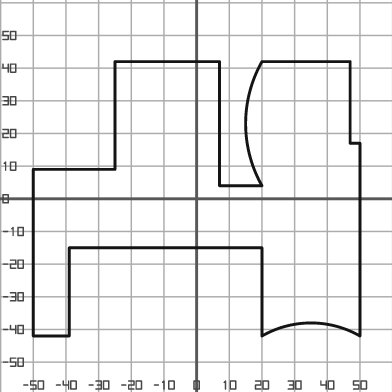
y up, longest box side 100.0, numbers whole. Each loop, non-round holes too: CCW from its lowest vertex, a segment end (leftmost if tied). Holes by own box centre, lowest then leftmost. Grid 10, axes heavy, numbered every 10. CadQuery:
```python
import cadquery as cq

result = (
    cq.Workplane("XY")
    .moveTo(-50.0, -42.0)
    .lineTo(-39.0, -42.0)
    .lineTo(-39.0, -15.0)
    .lineTo(20.0, -15.0)
    .lineTo(20.0, -42.0)
    .threePointArc((35.0, -38.0), (50.0, -42.0))
    .lineTo(50.0, 17.0)
    .lineTo(47.0, 17.0)
    .lineTo(47.0, 42.0)
    .lineTo(20.0, 42.0)
    .threePointArc((15.0, 23.0), (20.0, 4.0))
    .lineTo(7.0, 4.0)
    .lineTo(7.0, 42.0)
    .lineTo(-25.0, 42.0)
    .lineTo(-25.0, 9.0)
    .lineTo(-50.0, 9.0)
    .close()
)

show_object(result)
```